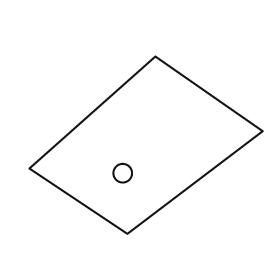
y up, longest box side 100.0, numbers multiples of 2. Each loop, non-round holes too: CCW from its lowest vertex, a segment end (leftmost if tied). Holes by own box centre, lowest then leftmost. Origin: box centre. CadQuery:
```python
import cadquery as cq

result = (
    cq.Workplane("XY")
    .moveTo(-8.0, -38.0)
    .lineTo(50.0, 6.0)
    .lineTo(4.0, 38.0)
    .lineTo(-50.0, -10.0)
    .close()
    .moveTo(-10.0, -12.0)
    .circle(4.0)
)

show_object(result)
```